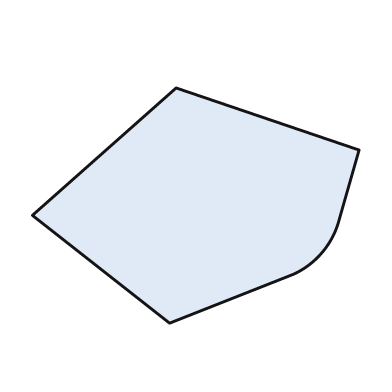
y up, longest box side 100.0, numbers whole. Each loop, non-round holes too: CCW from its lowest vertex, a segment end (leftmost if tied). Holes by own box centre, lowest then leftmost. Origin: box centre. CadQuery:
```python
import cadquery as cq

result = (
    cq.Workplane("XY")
    .moveTo(-8.0, -36.0)
    .lineTo(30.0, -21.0)
    .threePointArc((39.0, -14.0), (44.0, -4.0))
    .lineTo(50.0, 17.0)
    .lineTo(-6.0, 36.0)
    .lineTo(-50.0, -3.0)
    .close()
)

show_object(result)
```